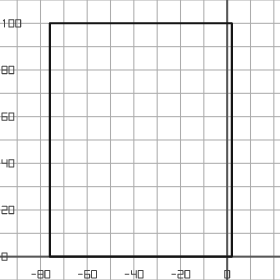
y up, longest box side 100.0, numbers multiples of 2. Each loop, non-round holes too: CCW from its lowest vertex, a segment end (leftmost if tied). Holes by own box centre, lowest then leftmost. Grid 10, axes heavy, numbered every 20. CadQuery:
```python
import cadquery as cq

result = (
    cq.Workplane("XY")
    .moveTo(-76.0, 0.0)
    .lineTo(2.0, 0.0)
    .lineTo(2.0, 100.0)
    .lineTo(-76.0, 100.0)
    .close()
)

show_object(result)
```